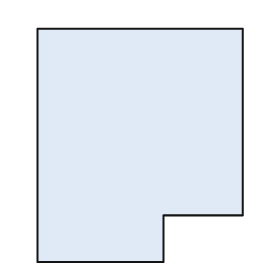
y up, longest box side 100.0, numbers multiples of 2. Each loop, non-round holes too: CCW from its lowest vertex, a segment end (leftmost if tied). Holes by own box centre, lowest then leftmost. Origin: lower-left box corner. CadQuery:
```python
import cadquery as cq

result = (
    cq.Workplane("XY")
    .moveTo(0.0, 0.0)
    .lineTo(54.0, 0.0)
    .lineTo(54.0, 20.0)
    .lineTo(88.0, 20.0)
    .lineTo(88.0, 100.0)
    .lineTo(0.0, 100.0)
    .close()
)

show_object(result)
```